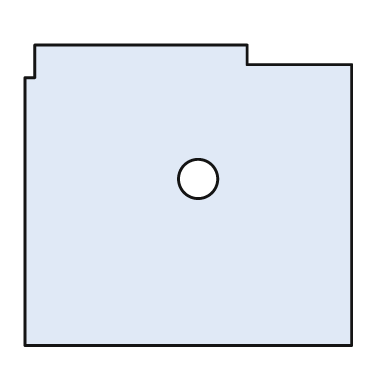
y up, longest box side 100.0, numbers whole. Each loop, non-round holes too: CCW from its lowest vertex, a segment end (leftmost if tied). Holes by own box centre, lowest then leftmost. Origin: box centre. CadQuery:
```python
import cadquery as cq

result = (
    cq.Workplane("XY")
    .moveTo(-50.0, -46.0)
    .lineTo(50.0, -46.0)
    .lineTo(50.0, 40.0)
    .lineTo(18.0, 40.0)
    .lineTo(18.0, 46.0)
    .lineTo(-47.0, 46.0)
    .lineTo(-47.0, 36.0)
    .lineTo(-50.0, 36.0)
    .close()
    .moveTo(3.0, 5.0)
    .circle(6.0)
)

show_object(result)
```